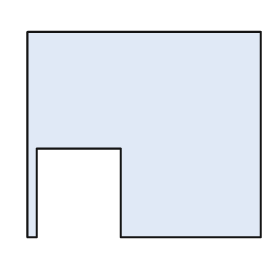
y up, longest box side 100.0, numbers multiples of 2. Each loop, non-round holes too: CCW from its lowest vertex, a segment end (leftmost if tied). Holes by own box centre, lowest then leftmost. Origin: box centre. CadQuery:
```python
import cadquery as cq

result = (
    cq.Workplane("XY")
    .moveTo(-50.0, -44.0)
    .lineTo(-46.0, -44.0)
    .lineTo(-46.0, -6.0)
    .lineTo(-10.0, -6.0)
    .lineTo(-10.0, -44.0)
    .lineTo(50.0, -44.0)
    .lineTo(50.0, 44.0)
    .lineTo(-50.0, 44.0)
    .close()
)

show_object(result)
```